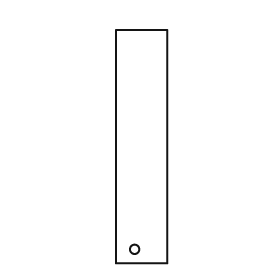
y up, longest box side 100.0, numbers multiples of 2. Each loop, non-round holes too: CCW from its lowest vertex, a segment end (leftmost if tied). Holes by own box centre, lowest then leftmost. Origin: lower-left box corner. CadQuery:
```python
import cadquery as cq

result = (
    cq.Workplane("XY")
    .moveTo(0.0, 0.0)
    .lineTo(22.0, 0.0)
    .lineTo(22.0, 100.0)
    .lineTo(0.0, 100.0)
    .close()
    .moveTo(8.0, 6.0)
    .circle(2.0)
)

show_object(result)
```